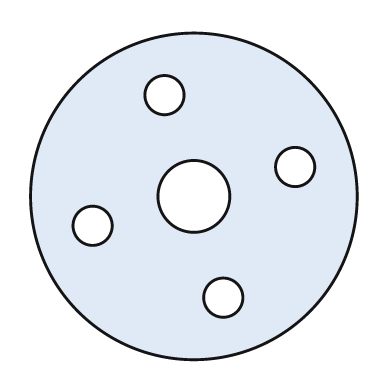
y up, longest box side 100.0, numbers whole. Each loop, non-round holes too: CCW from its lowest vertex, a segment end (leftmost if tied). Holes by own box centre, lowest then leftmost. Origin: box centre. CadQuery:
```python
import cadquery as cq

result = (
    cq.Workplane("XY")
    .moveTo(0.0, 0.0)
    .circle(50.0)
    .moveTo(9.0, -31.0)
    .circle(6.0)
    .moveTo(-31.0, -9.0)
    .circle(6.0)
    .moveTo(0.0, 0.0)
    .circle(11.0)
    .moveTo(31.0, 9.0)
    .circle(6.0)
    .moveTo(-9.0, 31.0)
    .circle(6.0)
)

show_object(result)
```